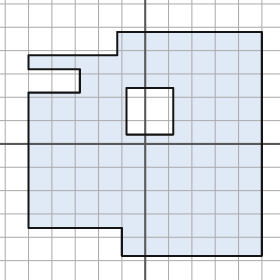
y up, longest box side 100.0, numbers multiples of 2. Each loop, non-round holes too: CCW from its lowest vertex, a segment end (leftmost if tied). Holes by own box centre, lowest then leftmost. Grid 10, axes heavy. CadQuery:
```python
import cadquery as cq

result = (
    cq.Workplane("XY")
    .moveTo(-10.0, -48.0)
    .lineTo(50.0, -48.0)
    .lineTo(50.0, 48.0)
    .lineTo(-12.0, 48.0)
    .lineTo(-12.0, 38.0)
    .lineTo(-50.0, 38.0)
    .lineTo(-50.0, 32.0)
    .lineTo(-28.0, 32.0)
    .lineTo(-28.0, 22.0)
    .lineTo(-50.0, 22.0)
    .lineTo(-50.0, -36.0)
    .lineTo(-10.0, -36.0)
    .close()
    .moveTo(-8.0, 4.0)
    .lineTo(12.0, 4.0)
    .lineTo(12.0, 24.0)
    .lineTo(-8.0, 24.0)
    .close()
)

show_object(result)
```